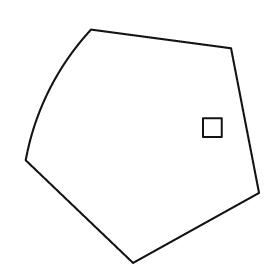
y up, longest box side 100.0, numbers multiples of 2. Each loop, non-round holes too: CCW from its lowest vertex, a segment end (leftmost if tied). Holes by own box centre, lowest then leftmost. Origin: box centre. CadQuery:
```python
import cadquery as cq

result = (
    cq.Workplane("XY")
    .moveTo(-4.0, -50.0)
    .lineTo(50.0, -20.0)
    .lineTo(38.0, 42.0)
    .lineTo(-22.0, 50.0)
    .threePointArc((-40.0, 24.0), (-50.0, -6.0))
    .close()
    .moveTo(26.0, 4.0)
    .lineTo(34.0, 4.0)
    .lineTo(34.0, 12.0)
    .lineTo(26.0, 12.0)
    .close()
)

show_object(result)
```